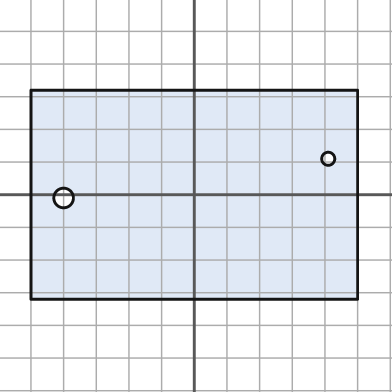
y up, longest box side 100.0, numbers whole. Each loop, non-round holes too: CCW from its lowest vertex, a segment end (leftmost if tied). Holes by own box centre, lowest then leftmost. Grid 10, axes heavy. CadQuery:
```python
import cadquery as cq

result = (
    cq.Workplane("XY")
    .moveTo(-50.0, -32.0)
    .lineTo(50.0, -32.0)
    .lineTo(50.0, 32.0)
    .lineTo(-50.0, 32.0)
    .close()
    .moveTo(-40.0, -1.0)
    .circle(3.0)
    .moveTo(41.0, 11.0)
    .circle(2.0)
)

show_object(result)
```